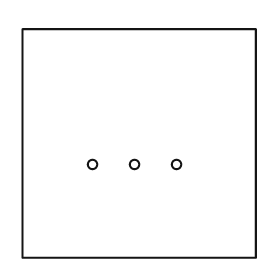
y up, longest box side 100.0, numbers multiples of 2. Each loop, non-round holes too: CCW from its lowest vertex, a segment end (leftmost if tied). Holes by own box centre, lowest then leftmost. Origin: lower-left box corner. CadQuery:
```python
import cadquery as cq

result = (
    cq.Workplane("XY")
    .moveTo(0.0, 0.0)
    .lineTo(100.0, 0.0)
    .lineTo(100.0, 98.0)
    .lineTo(0.0, 98.0)
    .close()
    .moveTo(30.0, 40.0)
    .circle(2.0)
    .moveTo(48.0, 40.0)
    .circle(2.0)
    .moveTo(66.0, 40.0)
    .circle(2.0)
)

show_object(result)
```